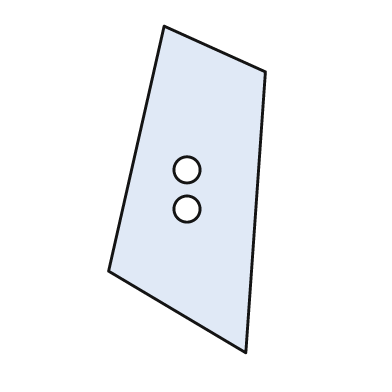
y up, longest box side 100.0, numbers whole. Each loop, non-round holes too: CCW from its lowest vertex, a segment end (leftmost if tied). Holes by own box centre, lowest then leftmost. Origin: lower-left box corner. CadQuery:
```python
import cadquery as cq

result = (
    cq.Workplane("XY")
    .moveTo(42.0, 0.0)
    .lineTo(48.0, 86.0)
    .lineTo(17.0, 100.0)
    .lineTo(0.0, 25.0)
    .close()
    .moveTo(24.0, 44.0)
    .circle(4.0)
    .moveTo(24.0, 56.0)
    .circle(4.0)
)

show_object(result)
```